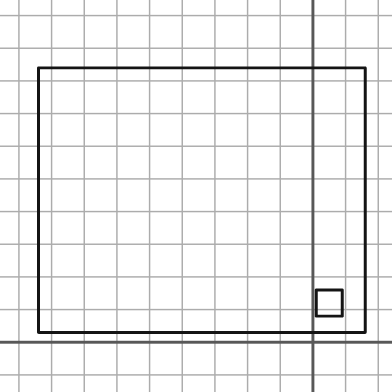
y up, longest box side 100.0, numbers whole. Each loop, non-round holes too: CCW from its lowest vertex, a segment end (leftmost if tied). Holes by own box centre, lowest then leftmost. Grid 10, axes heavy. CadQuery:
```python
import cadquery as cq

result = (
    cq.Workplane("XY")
    .moveTo(-84.0, 3.0)
    .lineTo(16.0, 3.0)
    .lineTo(16.0, 84.0)
    .lineTo(-84.0, 84.0)
    .close()
    .moveTo(1.0, 8.0)
    .lineTo(9.0, 8.0)
    .lineTo(9.0, 16.0)
    .lineTo(1.0, 16.0)
    .close()
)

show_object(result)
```